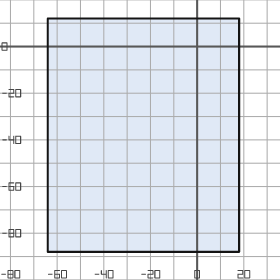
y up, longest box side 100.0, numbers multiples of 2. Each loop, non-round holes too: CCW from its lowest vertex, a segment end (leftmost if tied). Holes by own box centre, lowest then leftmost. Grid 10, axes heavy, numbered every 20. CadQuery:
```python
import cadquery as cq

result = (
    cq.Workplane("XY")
    .moveTo(-64.0, -88.0)
    .lineTo(18.0, -88.0)
    .lineTo(18.0, 12.0)
    .lineTo(-64.0, 12.0)
    .close()
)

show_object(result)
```